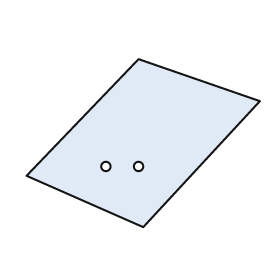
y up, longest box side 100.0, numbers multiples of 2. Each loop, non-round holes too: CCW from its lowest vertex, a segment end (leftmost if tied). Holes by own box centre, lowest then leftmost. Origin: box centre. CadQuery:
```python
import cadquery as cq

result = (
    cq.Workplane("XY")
    .moveTo(0.0, -36.0)
    .lineTo(50.0, 18.0)
    .lineTo(-2.0, 36.0)
    .lineTo(-50.0, -14.0)
    .close()
    .moveTo(-16.0, -10.0)
    .circle(2.0)
    .moveTo(-2.0, -10.0)
    .circle(2.0)
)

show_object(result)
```